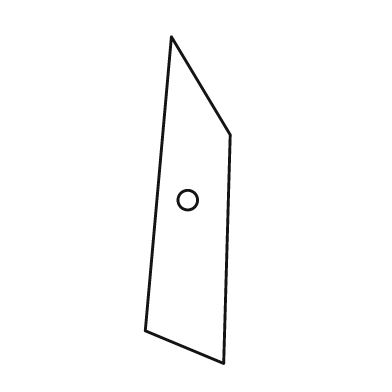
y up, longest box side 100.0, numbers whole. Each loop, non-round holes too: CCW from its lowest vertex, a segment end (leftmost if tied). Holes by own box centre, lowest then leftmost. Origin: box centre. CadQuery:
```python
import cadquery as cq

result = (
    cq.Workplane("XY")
    .moveTo(11.0, -50.0)
    .lineTo(13.0, 20.0)
    .lineTo(-5.0, 50.0)
    .lineTo(-13.0, -40.0)
    .close()
    .moveTo(0.0, 0.0)
    .circle(3.0)
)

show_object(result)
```